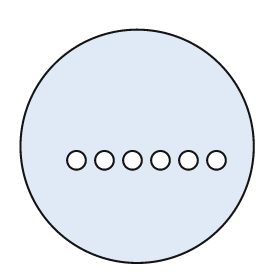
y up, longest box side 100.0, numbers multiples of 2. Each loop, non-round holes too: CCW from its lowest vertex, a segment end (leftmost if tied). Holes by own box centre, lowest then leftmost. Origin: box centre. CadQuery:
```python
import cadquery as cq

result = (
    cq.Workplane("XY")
    .moveTo(0.0, 0.0)
    .circle(50.0)
    .moveTo(-26.0, -6.0)
    .circle(4.0)
    .moveTo(-14.0, -6.0)
    .circle(4.0)
    .moveTo(-2.0, -6.0)
    .circle(4.0)
    .moveTo(10.0, -6.0)
    .circle(4.0)
    .moveTo(22.0, -6.0)
    .circle(4.0)
    .moveTo(34.0, -6.0)
    .circle(4.0)
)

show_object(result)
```